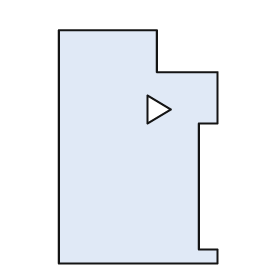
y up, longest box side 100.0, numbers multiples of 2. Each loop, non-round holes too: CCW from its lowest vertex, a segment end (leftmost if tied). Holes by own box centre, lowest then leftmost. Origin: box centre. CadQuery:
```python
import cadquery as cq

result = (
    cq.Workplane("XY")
    .moveTo(-34.0, -50.0)
    .lineTo(34.0, -50.0)
    .lineTo(34.0, -44.0)
    .lineTo(26.0, -44.0)
    .lineTo(26.0, 10.0)
    .lineTo(34.0, 10.0)
    .lineTo(34.0, 32.0)
    .lineTo(8.0, 32.0)
    .lineTo(8.0, 50.0)
    .lineTo(-34.0, 50.0)
    .close()
    .moveTo(4.0, 10.0)
    .lineTo(14.0, 16.0)
    .lineTo(4.0, 22.0)
    .close()
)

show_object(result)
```